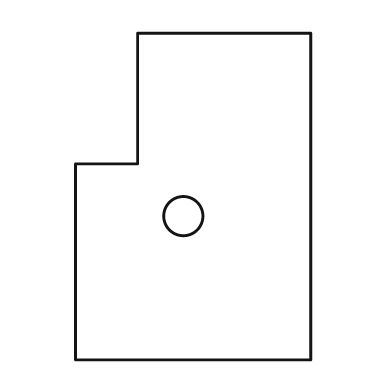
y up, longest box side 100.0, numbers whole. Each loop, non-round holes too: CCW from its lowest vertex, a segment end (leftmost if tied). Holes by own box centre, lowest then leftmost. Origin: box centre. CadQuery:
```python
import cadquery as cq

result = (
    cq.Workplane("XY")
    .moveTo(-36.0, -50.0)
    .lineTo(36.0, -50.0)
    .lineTo(36.0, 50.0)
    .lineTo(-17.0, 50.0)
    .lineTo(-17.0, 10.0)
    .lineTo(-36.0, 10.0)
    .close()
    .moveTo(-3.0, -6.0)
    .circle(6.0)
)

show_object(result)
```